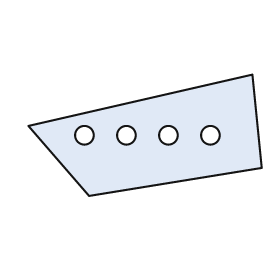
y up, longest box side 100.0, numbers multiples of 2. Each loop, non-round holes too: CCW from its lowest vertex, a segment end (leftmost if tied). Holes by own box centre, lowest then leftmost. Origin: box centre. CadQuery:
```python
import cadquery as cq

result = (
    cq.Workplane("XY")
    .moveTo(-24.0, -26.0)
    .lineTo(50.0, -14.0)
    .lineTo(46.0, 26.0)
    .lineTo(-50.0, 4.0)
    .close()
    .moveTo(-26.0, 0.0)
    .circle(4.0)
    .moveTo(-8.0, 0.0)
    .circle(4.0)
    .moveTo(10.0, 0.0)
    .circle(4.0)
    .moveTo(28.0, 0.0)
    .circle(4.0)
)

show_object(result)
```